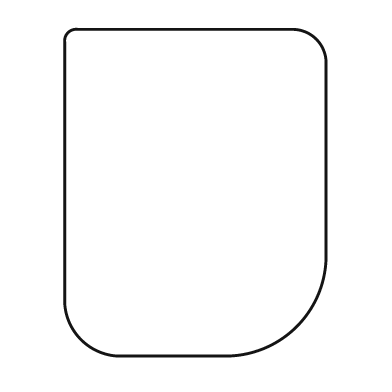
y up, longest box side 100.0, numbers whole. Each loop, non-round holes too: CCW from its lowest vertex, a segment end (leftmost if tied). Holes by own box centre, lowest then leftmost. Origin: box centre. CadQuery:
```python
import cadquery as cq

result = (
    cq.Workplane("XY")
    .moveTo(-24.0, -50.0)
    .lineTo(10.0, -50.0)
    .threePointArc((31.0, -41.0), (40.0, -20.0))
    .lineTo(40.0, 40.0)
    .threePointArc((37.0, 47.0), (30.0, 50.0))
    .lineTo(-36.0, 50.0)
    .threePointArc((-39.0, 49.0), (-40.0, 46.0))
    .lineTo(-40.0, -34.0)
    .threePointArc((-35.0, -45.0), (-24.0, -50.0))
    .close()
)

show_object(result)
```